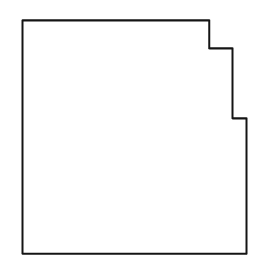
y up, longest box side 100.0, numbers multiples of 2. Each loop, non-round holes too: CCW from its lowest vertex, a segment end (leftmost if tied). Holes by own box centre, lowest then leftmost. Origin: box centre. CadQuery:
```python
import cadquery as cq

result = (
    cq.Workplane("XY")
    .moveTo(-48.0, -50.0)
    .lineTo(48.0, -50.0)
    .lineTo(48.0, 8.0)
    .lineTo(42.0, 8.0)
    .lineTo(42.0, 38.0)
    .lineTo(32.0, 38.0)
    .lineTo(32.0, 50.0)
    .lineTo(-48.0, 50.0)
    .close()
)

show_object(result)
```